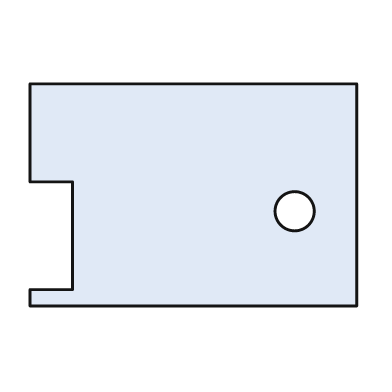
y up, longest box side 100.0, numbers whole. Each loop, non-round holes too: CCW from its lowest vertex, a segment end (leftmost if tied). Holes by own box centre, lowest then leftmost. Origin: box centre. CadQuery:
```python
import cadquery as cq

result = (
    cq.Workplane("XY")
    .moveTo(-50.0, -34.0)
    .lineTo(50.0, -34.0)
    .lineTo(50.0, 34.0)
    .lineTo(-50.0, 34.0)
    .lineTo(-50.0, 4.0)
    .lineTo(-37.0, 4.0)
    .lineTo(-37.0, -29.0)
    .lineTo(-50.0, -29.0)
    .close()
    .moveTo(31.0, -5.0)
    .circle(6.0)
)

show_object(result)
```